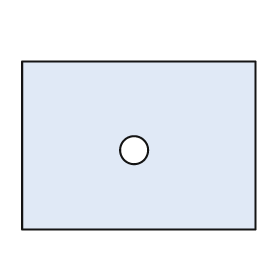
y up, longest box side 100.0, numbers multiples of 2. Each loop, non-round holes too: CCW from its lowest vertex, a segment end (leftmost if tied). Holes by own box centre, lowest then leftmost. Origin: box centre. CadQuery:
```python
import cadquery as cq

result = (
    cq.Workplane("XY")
    .moveTo(-50.0, -36.0)
    .lineTo(50.0, -36.0)
    .lineTo(50.0, 36.0)
    .lineTo(-50.0, 36.0)
    .close()
    .moveTo(-2.0, -2.0)
    .circle(6.0)
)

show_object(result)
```